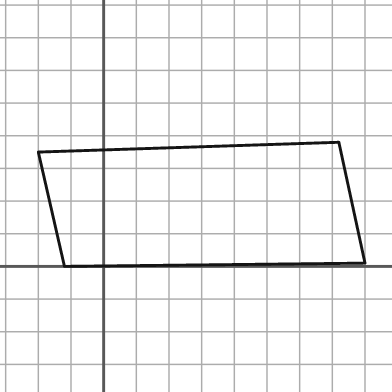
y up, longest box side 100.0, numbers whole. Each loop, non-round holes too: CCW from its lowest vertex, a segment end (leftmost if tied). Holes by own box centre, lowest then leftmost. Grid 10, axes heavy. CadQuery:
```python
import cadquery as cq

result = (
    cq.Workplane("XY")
    .moveTo(-12.0, 0.0)
    .lineTo(80.0, 1.0)
    .lineTo(72.0, 38.0)
    .lineTo(-20.0, 35.0)
    .close()
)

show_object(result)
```